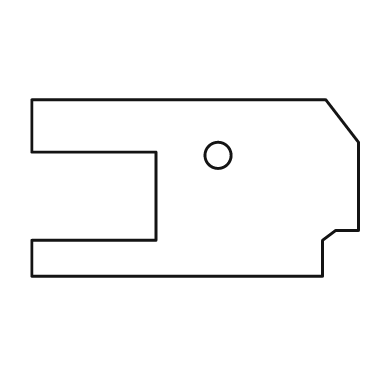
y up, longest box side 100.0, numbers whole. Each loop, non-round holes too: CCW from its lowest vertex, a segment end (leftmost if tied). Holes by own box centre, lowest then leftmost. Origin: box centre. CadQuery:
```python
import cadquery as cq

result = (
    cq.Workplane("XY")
    .moveTo(-50.0, -27.0)
    .lineTo(39.0, -27.0)
    .lineTo(39.0, -16.0)
    .lineTo(43.0, -13.0)
    .lineTo(50.0, -13.0)
    .lineTo(50.0, 14.0)
    .lineTo(40.0, 27.0)
    .lineTo(-50.0, 27.0)
    .lineTo(-50.0, 11.0)
    .lineTo(-12.0, 11.0)
    .lineTo(-12.0, -16.0)
    .lineTo(-50.0, -16.0)
    .close()
    .moveTo(7.0, 10.0)
    .circle(4.0)
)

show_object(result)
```